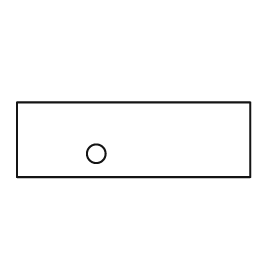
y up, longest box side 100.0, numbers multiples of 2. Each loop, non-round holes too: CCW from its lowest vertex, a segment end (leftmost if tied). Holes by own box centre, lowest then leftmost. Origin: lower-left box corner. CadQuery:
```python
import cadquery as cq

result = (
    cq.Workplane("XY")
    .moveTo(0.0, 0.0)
    .lineTo(100.0, 0.0)
    .lineTo(100.0, 32.0)
    .lineTo(0.0, 32.0)
    .close()
    .moveTo(34.0, 10.0)
    .circle(4.0)
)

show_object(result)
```